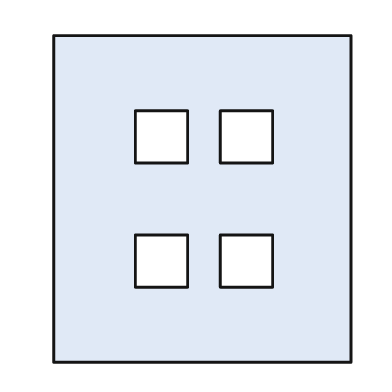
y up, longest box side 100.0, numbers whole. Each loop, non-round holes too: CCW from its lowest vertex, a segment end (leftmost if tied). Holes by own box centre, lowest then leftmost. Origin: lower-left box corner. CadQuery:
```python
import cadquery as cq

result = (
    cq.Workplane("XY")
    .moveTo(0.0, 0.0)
    .lineTo(91.0, 0.0)
    .lineTo(91.0, 100.0)
    .lineTo(0.0, 100.0)
    .close()
    .moveTo(25.0, 23.0)
    .lineTo(41.0, 23.0)
    .lineTo(41.0, 39.0)
    .lineTo(25.0, 39.0)
    .close()
    .moveTo(51.0, 23.0)
    .lineTo(67.0, 23.0)
    .lineTo(67.0, 39.0)
    .lineTo(51.0, 39.0)
    .close()
    .moveTo(25.0, 61.0)
    .lineTo(41.0, 61.0)
    .lineTo(41.0, 77.0)
    .lineTo(25.0, 77.0)
    .close()
    .moveTo(51.0, 61.0)
    .lineTo(67.0, 61.0)
    .lineTo(67.0, 77.0)
    .lineTo(51.0, 77.0)
    .close()
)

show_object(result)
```